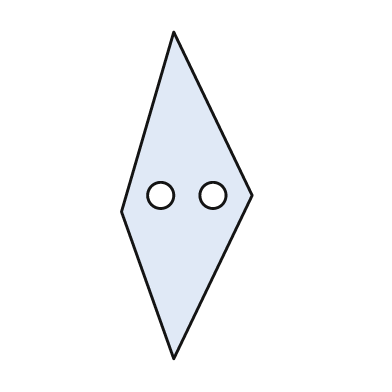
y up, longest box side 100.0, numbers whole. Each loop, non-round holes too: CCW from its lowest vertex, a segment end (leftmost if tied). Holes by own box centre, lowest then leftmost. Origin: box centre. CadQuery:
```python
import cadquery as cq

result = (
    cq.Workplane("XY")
    .moveTo(-4.0, -50.0)
    .lineTo(20.0, 0.0)
    .lineTo(-4.0, 50.0)
    .lineTo(-20.0, -5.0)
    .close()
    .moveTo(-8.0, 0.0)
    .circle(4.0)
    .moveTo(8.0, 0.0)
    .circle(4.0)
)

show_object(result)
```